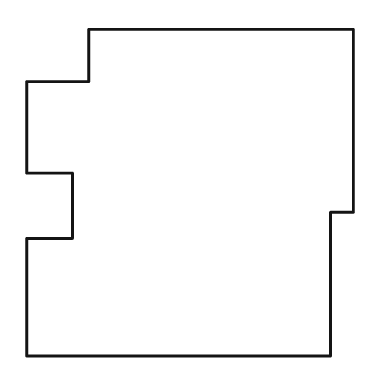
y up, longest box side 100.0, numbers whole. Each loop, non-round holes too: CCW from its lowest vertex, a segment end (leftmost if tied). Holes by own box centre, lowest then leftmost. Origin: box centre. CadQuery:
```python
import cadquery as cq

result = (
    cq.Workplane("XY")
    .moveTo(-50.0, -50.0)
    .lineTo(43.0, -50.0)
    .lineTo(43.0, -6.0)
    .lineTo(50.0, -6.0)
    .lineTo(50.0, 50.0)
    .lineTo(-31.0, 50.0)
    .lineTo(-31.0, 34.0)
    .lineTo(-50.0, 34.0)
    .lineTo(-50.0, 6.0)
    .lineTo(-36.0, 6.0)
    .lineTo(-36.0, -14.0)
    .lineTo(-50.0, -14.0)
    .close()
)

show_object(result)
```